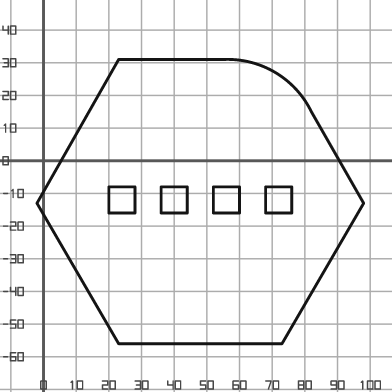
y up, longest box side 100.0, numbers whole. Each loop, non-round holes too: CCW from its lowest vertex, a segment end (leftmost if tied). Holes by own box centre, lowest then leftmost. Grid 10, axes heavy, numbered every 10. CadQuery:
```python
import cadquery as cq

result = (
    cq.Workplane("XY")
    .moveTo(23.0, -56.0)
    .lineTo(73.0, -56.0)
    .lineTo(98.0, -13.0)
    .lineTo(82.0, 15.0)
    .threePointArc((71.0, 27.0), (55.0, 31.0))
    .lineTo(23.0, 31.0)
    .lineTo(-2.0, -13.0)
    .close()
    .moveTo(20.0, -16.0)
    .lineTo(28.0, -16.0)
    .lineTo(28.0, -8.0)
    .lineTo(20.0, -8.0)
    .close()
    .moveTo(36.0, -16.0)
    .lineTo(44.0, -16.0)
    .lineTo(44.0, -8.0)
    .lineTo(36.0, -8.0)
    .close()
    .moveTo(52.0, -16.0)
    .lineTo(60.0, -16.0)
    .lineTo(60.0, -8.0)
    .lineTo(52.0, -8.0)
    .close()
    .moveTo(68.0, -16.0)
    .lineTo(76.0, -16.0)
    .lineTo(76.0, -8.0)
    .lineTo(68.0, -8.0)
    .close()
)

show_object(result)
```